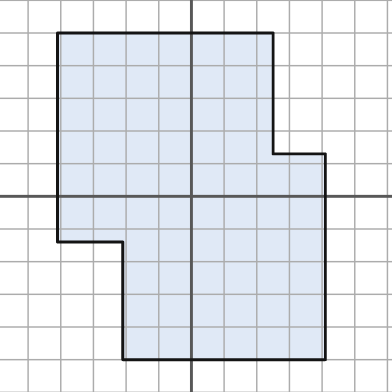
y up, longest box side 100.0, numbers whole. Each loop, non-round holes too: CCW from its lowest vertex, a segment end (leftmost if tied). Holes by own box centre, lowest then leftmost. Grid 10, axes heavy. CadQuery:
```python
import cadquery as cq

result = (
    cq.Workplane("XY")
    .moveTo(-21.0, -50.0)
    .lineTo(41.0, -50.0)
    .lineTo(41.0, 13.0)
    .lineTo(25.0, 13.0)
    .lineTo(25.0, 50.0)
    .lineTo(-41.0, 50.0)
    .lineTo(-41.0, -14.0)
    .lineTo(-21.0, -14.0)
    .close()
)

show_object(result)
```